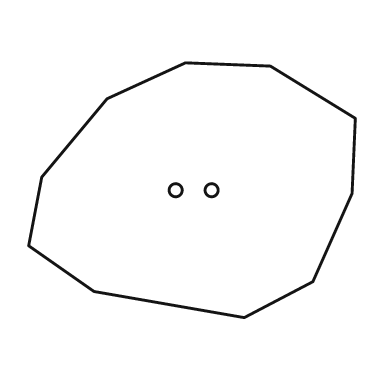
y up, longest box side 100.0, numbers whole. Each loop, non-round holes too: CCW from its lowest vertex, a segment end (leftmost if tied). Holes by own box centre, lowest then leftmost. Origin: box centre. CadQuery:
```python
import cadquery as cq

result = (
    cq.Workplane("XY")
    .moveTo(16.0, -39.0)
    .lineTo(37.0, -28.0)
    .lineTo(49.0, -1.0)
    .lineTo(50.0, 22.0)
    .lineTo(24.0, 38.0)
    .lineTo(-2.0, 39.0)
    .lineTo(-26.0, 28.0)
    .lineTo(-46.0, 4.0)
    .lineTo(-50.0, -17.0)
    .lineTo(-30.0, -31.0)
    .close()
    .moveTo(-5.0, 0.0)
    .circle(2.0)
    .moveTo(6.0, 0.0)
    .circle(2.0)
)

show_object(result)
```